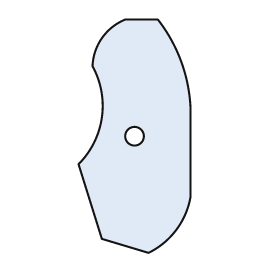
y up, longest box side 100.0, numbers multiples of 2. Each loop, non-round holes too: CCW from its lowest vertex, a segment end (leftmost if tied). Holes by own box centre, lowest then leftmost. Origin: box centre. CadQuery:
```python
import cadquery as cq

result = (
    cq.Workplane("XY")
    .moveTo(6.0, -50.0)
    .threePointArc((18.0, -40.0), (24.0, -26.0))
    .lineTo(24.0, 12.0)
    .threePointArc((20.0, 32.0), (10.0, 50.0))
    .lineTo(-4.0, 50.0)
    .threePointArc((-14.0, 42.0), (-18.0, 30.0))
    .threePointArc((-14.0, 8.0), (-24.0, -12.0))
    .lineTo(-14.0, -44.0)
    .close()
    .moveTo(0.0, 0.0)
    .circle(4.0)
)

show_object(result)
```